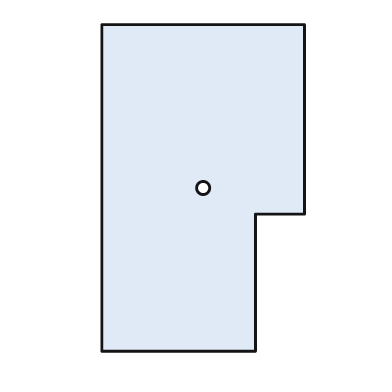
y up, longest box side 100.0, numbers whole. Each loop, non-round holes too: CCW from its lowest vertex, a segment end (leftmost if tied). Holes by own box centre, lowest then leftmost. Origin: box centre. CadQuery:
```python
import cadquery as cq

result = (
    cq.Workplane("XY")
    .moveTo(-31.0, -50.0)
    .lineTo(16.0, -50.0)
    .lineTo(16.0, -8.0)
    .lineTo(31.0, -8.0)
    .lineTo(31.0, 50.0)
    .lineTo(-31.0, 50.0)
    .close()
    .moveTo(0.0, 0.0)
    .circle(2.0)
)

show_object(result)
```